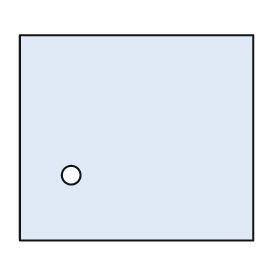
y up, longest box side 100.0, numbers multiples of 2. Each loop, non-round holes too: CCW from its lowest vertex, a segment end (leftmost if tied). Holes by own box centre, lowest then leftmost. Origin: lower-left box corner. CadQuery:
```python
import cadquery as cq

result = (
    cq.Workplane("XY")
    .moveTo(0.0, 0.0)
    .lineTo(100.0, 0.0)
    .lineTo(100.0, 88.0)
    .lineTo(0.0, 88.0)
    .close()
    .moveTo(22.0, 28.0)
    .circle(4.0)
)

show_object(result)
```